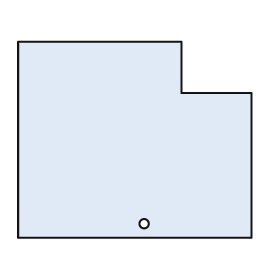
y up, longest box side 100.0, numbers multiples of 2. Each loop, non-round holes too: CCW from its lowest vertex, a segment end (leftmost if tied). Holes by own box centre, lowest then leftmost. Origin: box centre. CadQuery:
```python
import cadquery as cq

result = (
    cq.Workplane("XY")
    .moveTo(-50.0, -42.0)
    .lineTo(50.0, -42.0)
    .lineTo(50.0, 20.0)
    .lineTo(20.0, 20.0)
    .lineTo(20.0, 42.0)
    .lineTo(-50.0, 42.0)
    .close()
    .moveTo(4.0, -36.0)
    .circle(2.0)
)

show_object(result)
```